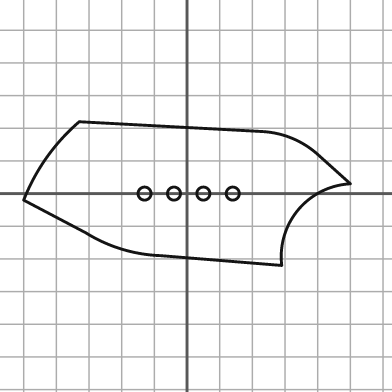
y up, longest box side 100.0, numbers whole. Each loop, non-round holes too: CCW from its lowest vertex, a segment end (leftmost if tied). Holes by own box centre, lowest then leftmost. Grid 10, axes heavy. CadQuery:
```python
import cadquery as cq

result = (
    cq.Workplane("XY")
    .moveTo(29.0, -22.0)
    .threePointArc((34.0, -5.0), (50.0, 3.0))
    .lineTo(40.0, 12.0)
    .threePointArc((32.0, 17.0), (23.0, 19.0))
    .lineTo(-33.0, 22.0)
    .threePointArc((-43.0, 11.0), (-50.0, -2.0))
    .lineTo(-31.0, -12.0)
    .threePointArc((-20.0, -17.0), (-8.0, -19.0))
    .close()
    .moveTo(-13.0, 0.0)
    .circle(2.0)
    .moveTo(-4.0, 0.0)
    .circle(2.0)
    .moveTo(5.0, 0.0)
    .circle(2.0)
    .moveTo(14.0, 0.0)
    .circle(2.0)
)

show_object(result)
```